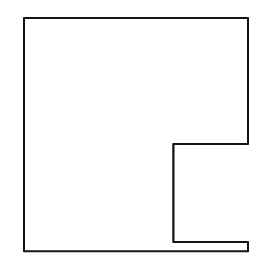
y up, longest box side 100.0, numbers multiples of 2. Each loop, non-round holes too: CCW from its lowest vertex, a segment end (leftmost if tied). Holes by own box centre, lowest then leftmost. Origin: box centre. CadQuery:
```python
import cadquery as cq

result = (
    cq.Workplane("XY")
    .moveTo(-48.0, -50.0)
    .lineTo(48.0, -50.0)
    .lineTo(48.0, -46.0)
    .lineTo(16.0, -46.0)
    .lineTo(16.0, -4.0)
    .lineTo(48.0, -4.0)
    .lineTo(48.0, 50.0)
    .lineTo(-48.0, 50.0)
    .close()
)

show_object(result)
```